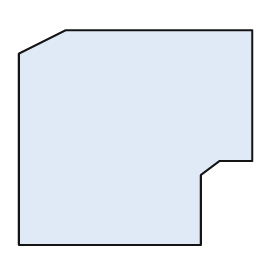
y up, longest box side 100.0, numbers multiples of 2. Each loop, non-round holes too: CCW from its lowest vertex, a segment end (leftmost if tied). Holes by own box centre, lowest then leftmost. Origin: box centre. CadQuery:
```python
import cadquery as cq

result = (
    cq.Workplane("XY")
    .moveTo(-50.0, -46.0)
    .lineTo(28.0, -46.0)
    .lineTo(28.0, -16.0)
    .lineTo(36.0, -10.0)
    .lineTo(50.0, -10.0)
    .lineTo(50.0, 46.0)
    .lineTo(-30.0, 46.0)
    .lineTo(-50.0, 36.0)
    .close()
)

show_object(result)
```